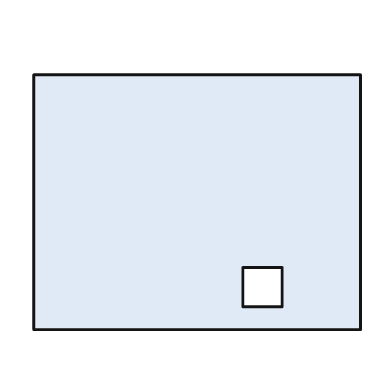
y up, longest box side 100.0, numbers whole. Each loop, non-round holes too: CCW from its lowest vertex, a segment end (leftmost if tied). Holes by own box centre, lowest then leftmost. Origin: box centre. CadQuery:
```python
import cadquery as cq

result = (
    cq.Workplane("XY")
    .moveTo(-50.0, -39.0)
    .lineTo(50.0, -39.0)
    .lineTo(50.0, 39.0)
    .lineTo(-50.0, 39.0)
    .close()
    .moveTo(14.0, -32.0)
    .lineTo(26.0, -32.0)
    .lineTo(26.0, -20.0)
    .lineTo(14.0, -20.0)
    .close()
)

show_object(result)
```